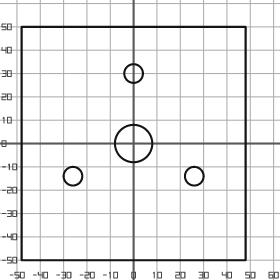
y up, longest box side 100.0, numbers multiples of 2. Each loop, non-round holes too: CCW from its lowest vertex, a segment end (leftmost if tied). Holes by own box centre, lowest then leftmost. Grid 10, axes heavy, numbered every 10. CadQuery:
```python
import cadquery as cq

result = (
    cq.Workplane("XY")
    .moveTo(-48.0, -50.0)
    .lineTo(48.0, -50.0)
    .lineTo(48.0, 50.0)
    .lineTo(-48.0, 50.0)
    .close()
    .moveTo(-26.0, -14.0)
    .circle(4.0)
    .moveTo(26.0, -14.0)
    .circle(4.0)
    .moveTo(0.0, 0.0)
    .circle(8.0)
    .moveTo(0.0, 30.0)
    .circle(4.0)
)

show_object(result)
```